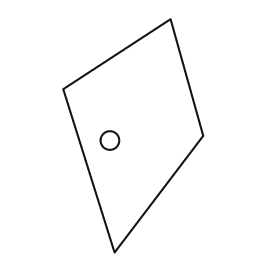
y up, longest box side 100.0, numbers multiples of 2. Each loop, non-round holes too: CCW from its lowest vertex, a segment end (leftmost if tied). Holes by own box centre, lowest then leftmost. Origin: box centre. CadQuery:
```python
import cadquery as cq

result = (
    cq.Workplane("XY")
    .moveTo(-8.0, -50.0)
    .lineTo(30.0, 0.0)
    .lineTo(16.0, 50.0)
    .lineTo(-30.0, 20.0)
    .close()
    .moveTo(-10.0, -2.0)
    .circle(4.0)
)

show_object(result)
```